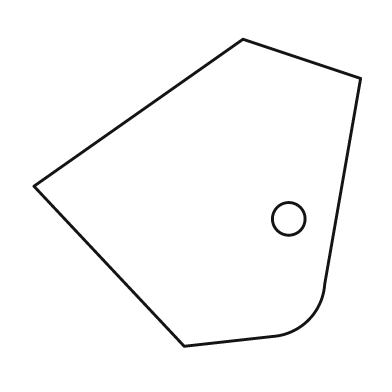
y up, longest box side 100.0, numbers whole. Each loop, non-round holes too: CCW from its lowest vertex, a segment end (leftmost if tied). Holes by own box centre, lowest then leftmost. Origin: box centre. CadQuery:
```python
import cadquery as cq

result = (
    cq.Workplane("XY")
    .moveTo(-4.0, -47.0)
    .lineTo(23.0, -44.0)
    .threePointArc((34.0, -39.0), (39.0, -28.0))
    .lineTo(50.0, 35.0)
    .lineTo(14.0, 47.0)
    .lineTo(-50.0, 2.0)
    .close()
    .moveTo(28.0, -8.0)
    .circle(5.0)
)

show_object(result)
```